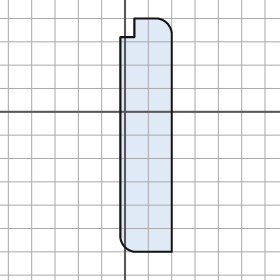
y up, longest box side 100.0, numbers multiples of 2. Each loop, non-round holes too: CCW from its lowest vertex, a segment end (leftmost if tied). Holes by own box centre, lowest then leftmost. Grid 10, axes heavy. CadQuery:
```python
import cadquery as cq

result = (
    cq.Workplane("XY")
    .moveTo(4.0, -60.0)
    .lineTo(20.0, -60.0)
    .lineTo(20.0, 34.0)
    .threePointArc((18.0, 38.0), (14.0, 40.0))
    .lineTo(4.0, 40.0)
    .lineTo(4.0, 32.0)
    .lineTo(-2.0, 32.0)
    .lineTo(-2.0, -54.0)
    .threePointArc((0.0, -58.0), (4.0, -60.0))
    .close()
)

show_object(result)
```